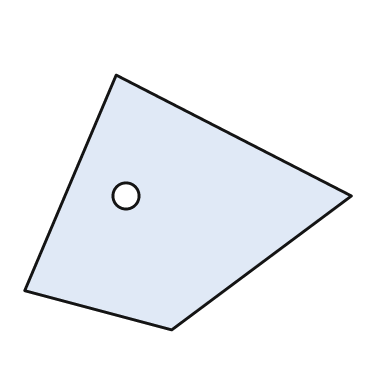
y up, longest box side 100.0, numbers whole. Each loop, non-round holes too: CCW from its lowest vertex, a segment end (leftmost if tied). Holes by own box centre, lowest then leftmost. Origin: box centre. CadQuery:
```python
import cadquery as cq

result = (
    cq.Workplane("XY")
    .moveTo(-5.0, -39.0)
    .lineTo(50.0, 2.0)
    .lineTo(-22.0, 39.0)
    .lineTo(-50.0, -27.0)
    .close()
    .moveTo(-19.0, 2.0)
    .circle(4.0)
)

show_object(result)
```